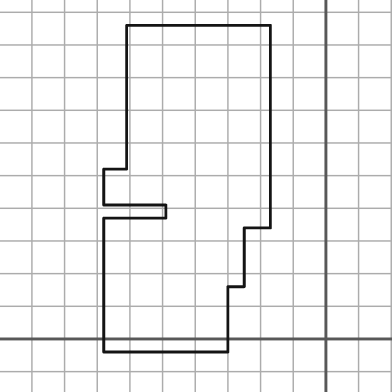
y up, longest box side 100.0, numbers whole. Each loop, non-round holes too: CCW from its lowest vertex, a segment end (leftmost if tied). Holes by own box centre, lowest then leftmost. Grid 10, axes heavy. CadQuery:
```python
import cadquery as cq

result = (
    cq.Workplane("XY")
    .moveTo(-68.0, -4.0)
    .lineTo(-30.0, -4.0)
    .lineTo(-30.0, 16.0)
    .lineTo(-25.0, 16.0)
    .lineTo(-25.0, 34.0)
    .lineTo(-17.0, 34.0)
    .lineTo(-17.0, 96.0)
    .lineTo(-61.0, 96.0)
    .lineTo(-61.0, 52.0)
    .lineTo(-68.0, 52.0)
    .lineTo(-68.0, 41.0)
    .lineTo(-49.0, 41.0)
    .lineTo(-49.0, 37.0)
    .lineTo(-68.0, 37.0)
    .close()
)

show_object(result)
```